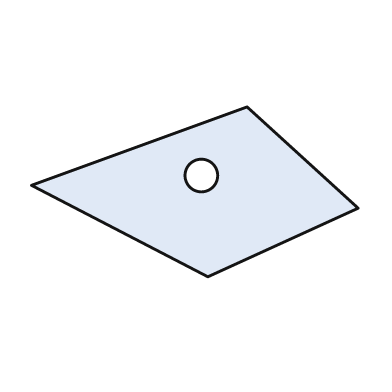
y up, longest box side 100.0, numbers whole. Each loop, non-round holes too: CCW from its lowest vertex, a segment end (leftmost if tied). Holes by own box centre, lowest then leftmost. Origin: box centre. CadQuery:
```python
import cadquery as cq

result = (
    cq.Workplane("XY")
    .moveTo(4.0, -26.0)
    .lineTo(50.0, -5.0)
    .lineTo(16.0, 26.0)
    .lineTo(-50.0, 2.0)
    .close()
    .moveTo(2.0, 5.0)
    .circle(5.0)
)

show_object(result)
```